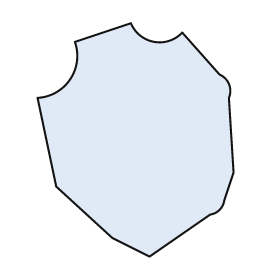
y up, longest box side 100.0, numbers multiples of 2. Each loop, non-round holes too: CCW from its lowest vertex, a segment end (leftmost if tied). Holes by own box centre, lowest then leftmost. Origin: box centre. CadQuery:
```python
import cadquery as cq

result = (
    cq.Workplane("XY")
    .moveTo(6.0, -50.0)
    .lineTo(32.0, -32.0)
    .threePointArc((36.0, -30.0), (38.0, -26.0))
    .lineTo(42.0, -14.0)
    .lineTo(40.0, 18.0)
    .threePointArc((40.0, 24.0), (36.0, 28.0))
    .lineTo(20.0, 46.0)
    .threePointArc((8.0, 42.0), (-2.0, 50.0))
    .lineTo(-26.0, 42.0)
    .threePointArc((-28.0, 26.0), (-42.0, 18.0))
    .lineTo(-34.0, -20.0)
    .lineTo(-10.0, -42.0)
    .close()
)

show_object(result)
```